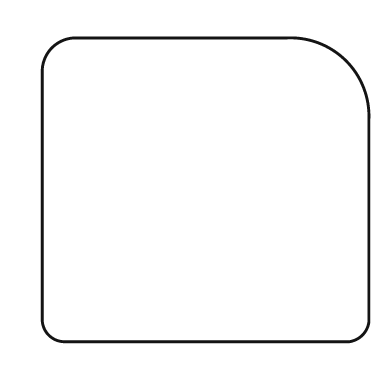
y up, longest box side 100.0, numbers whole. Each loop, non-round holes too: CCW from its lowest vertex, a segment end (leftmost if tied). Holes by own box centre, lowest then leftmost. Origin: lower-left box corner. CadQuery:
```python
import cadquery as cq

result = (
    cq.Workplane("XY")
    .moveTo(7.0, 0.0)
    .lineTo(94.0, 0.0)
    .threePointArc((98.0, 2.0), (100.0, 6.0))
    .lineTo(100.0, 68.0)
    .threePointArc((93.0, 86.0), (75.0, 93.0))
    .lineTo(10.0, 93.0)
    .threePointArc((3.0, 90.0), (0.0, 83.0))
    .lineTo(0.0, 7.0)
    .threePointArc((2.0, 2.0), (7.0, 0.0))
    .close()
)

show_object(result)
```